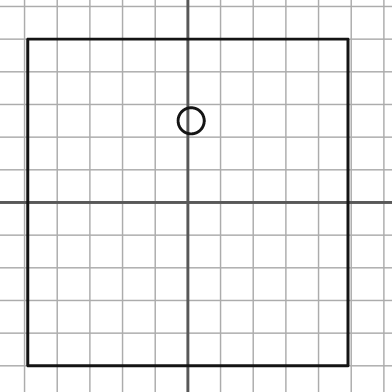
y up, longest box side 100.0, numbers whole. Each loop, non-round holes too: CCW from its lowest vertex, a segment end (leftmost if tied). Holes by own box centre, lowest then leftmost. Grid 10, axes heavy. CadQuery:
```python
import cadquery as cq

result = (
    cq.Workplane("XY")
    .moveTo(-49.0, -50.0)
    .lineTo(49.0, -50.0)
    .lineTo(49.0, 50.0)
    .lineTo(-49.0, 50.0)
    .close()
    .moveTo(1.0, 25.0)
    .circle(4.0)
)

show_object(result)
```